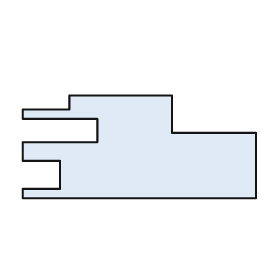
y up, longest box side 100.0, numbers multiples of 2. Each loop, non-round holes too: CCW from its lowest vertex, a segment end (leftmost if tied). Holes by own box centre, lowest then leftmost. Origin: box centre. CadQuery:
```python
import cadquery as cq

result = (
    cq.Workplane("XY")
    .moveTo(-50.0, -22.0)
    .lineTo(50.0, -22.0)
    .lineTo(50.0, 6.0)
    .lineTo(14.0, 6.0)
    .lineTo(14.0, 22.0)
    .lineTo(-30.0, 22.0)
    .lineTo(-30.0, 16.0)
    .lineTo(-50.0, 16.0)
    .lineTo(-50.0, 12.0)
    .lineTo(-18.0, 12.0)
    .lineTo(-18.0, 2.0)
    .lineTo(-50.0, 2.0)
    .lineTo(-50.0, -6.0)
    .lineTo(-34.0, -6.0)
    .lineTo(-34.0, -18.0)
    .lineTo(-50.0, -18.0)
    .close()
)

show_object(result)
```